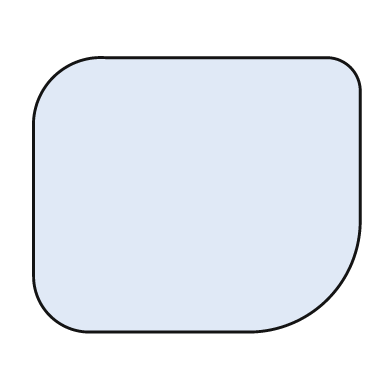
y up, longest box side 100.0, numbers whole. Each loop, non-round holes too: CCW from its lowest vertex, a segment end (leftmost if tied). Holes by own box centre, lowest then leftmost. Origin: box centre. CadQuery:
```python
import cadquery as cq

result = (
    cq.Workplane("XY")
    .moveTo(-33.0, -42.0)
    .lineTo(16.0, -42.0)
    .threePointArc((40.0, -32.0), (50.0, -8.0))
    .lineTo(50.0, 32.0)
    .threePointArc((47.0, 39.0), (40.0, 42.0))
    .lineTo(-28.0, 42.0)
    .threePointArc((-44.0, 36.0), (-50.0, 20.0))
    .lineTo(-50.0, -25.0)
    .threePointArc((-45.0, -37.0), (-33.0, -42.0))
    .close()
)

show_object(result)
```